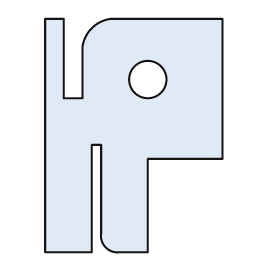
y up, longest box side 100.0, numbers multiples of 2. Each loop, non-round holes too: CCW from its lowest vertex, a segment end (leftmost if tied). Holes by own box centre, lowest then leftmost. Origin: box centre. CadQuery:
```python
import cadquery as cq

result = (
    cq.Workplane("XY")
    .moveTo(-38.0, -50.0)
    .lineTo(-18.0, -50.0)
    .lineTo(-18.0, -4.0)
    .lineTo(-14.0, -4.0)
    .lineTo(-14.0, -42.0)
    .threePointArc((-12.0, -48.0), (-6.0, -50.0))
    .lineTo(6.0, -50.0)
    .lineTo(6.0, -10.0)
    .lineTo(38.0, -10.0)
    .lineTo(38.0, 50.0)
    .lineTo(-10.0, 50.0)
    .threePointArc((-18.0, 46.0), (-22.0, 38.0))
    .lineTo(-22.0, 16.0)
    .lineTo(-30.0, 16.0)
    .lineTo(-30.0, 50.0)
    .lineTo(-38.0, 50.0)
    .close()
    .moveTo(6.0, 24.0)
    .circle(8.0)
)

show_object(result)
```